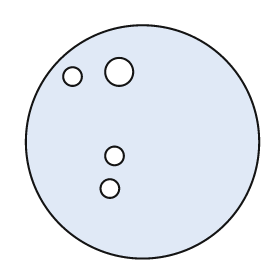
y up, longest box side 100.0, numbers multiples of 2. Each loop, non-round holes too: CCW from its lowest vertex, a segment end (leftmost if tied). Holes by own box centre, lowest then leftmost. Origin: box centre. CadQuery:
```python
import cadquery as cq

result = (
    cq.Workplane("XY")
    .moveTo(0.0, 0.0)
    .circle(50.0)
    .moveTo(-14.0, -20.0)
    .circle(4.0)
    .moveTo(-12.0, -6.0)
    .circle(4.0)
    .moveTo(-30.0, 28.0)
    .circle(4.0)
    .moveTo(-10.0, 30.0)
    .circle(6.0)
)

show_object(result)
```